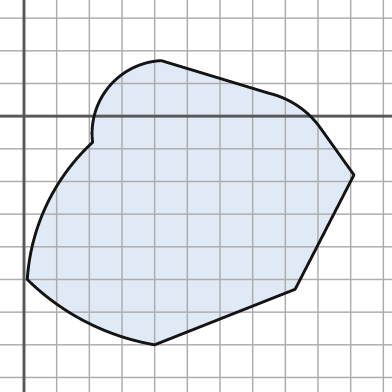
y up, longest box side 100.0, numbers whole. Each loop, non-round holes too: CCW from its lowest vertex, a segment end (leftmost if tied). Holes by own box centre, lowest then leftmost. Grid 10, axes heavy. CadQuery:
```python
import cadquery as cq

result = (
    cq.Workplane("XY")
    .moveTo(40.0, -70.0)
    .lineTo(83.0, -53.0)
    .lineTo(101.0, -18.0)
    .lineTo(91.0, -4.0)
    .threePointArc((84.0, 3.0), (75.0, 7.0))
    .lineTo(42.0, 17.0)
    .threePointArc((26.0, 9.0), (21.0, -8.0))
    .threePointArc((7.0, -27.0), (1.0, -50.0))
    .threePointArc((19.0, -63.0), (40.0, -70.0))
    .close()
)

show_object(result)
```